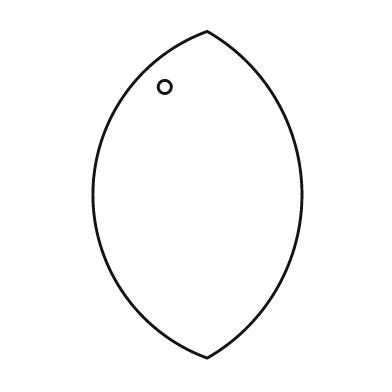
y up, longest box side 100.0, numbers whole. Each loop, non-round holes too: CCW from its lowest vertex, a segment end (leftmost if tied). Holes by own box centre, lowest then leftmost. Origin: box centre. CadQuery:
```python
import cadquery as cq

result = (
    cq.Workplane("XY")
    .moveTo(3.0, -50.0)
    .threePointArc((32.0, 0.0), (3.0, 50.0))
    .threePointArc((-32.0, 0.0), (3.0, -50.0))
    .close()
    .moveTo(-10.0, 33.0)
    .circle(2.0)
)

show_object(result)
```